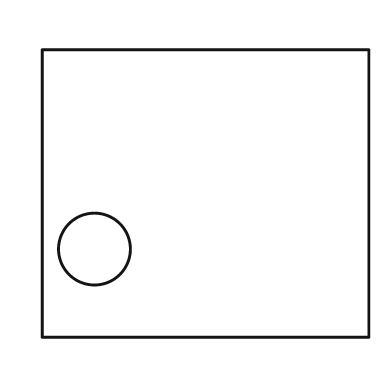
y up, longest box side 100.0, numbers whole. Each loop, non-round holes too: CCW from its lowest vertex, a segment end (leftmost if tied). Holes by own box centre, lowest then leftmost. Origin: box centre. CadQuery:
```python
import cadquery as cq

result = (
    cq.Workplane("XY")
    .moveTo(-50.0, -44.0)
    .lineTo(50.0, -44.0)
    .lineTo(50.0, 44.0)
    .lineTo(-50.0, 44.0)
    .close()
    .moveTo(-34.0, -17.0)
    .circle(11.0)
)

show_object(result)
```